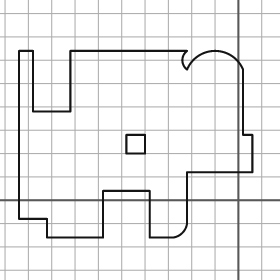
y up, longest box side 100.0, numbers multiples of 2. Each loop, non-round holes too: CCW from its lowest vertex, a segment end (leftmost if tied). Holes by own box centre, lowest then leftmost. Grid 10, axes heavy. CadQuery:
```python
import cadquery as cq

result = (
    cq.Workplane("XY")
    .moveTo(-82.0, -16.0)
    .lineTo(-58.0, -16.0)
    .lineTo(-58.0, 4.0)
    .lineTo(-38.0, 4.0)
    .lineTo(-38.0, -16.0)
    .lineTo(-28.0, -16.0)
    .threePointArc((-24.0, -14.0), (-22.0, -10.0))
    .lineTo(-22.0, 12.0)
    .lineTo(6.0, 12.0)
    .lineTo(6.0, 28.0)
    .lineTo(2.0, 28.0)
    .lineTo(2.0, 56.0)
    .threePointArc((-10.0, 64.0), (-22.0, 56.0))
    .threePointArc((-24.0, 60.0), (-22.0, 64.0))
    .lineTo(-72.0, 64.0)
    .lineTo(-72.0, 38.0)
    .lineTo(-88.0, 38.0)
    .lineTo(-88.0, 64.0)
    .lineTo(-94.0, 64.0)
    .lineTo(-94.0, -8.0)
    .lineTo(-82.0, -8.0)
    .close()
    .moveTo(-48.0, 20.0)
    .lineTo(-40.0, 20.0)
    .lineTo(-40.0, 28.0)
    .lineTo(-48.0, 28.0)
    .close()
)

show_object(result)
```